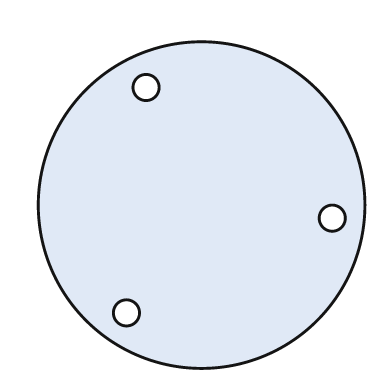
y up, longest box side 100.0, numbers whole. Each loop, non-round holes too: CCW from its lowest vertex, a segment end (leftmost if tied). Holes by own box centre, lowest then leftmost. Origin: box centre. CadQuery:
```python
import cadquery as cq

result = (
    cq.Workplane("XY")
    .moveTo(0.0, 0.0)
    .circle(50.0)
    .moveTo(-23.0, -33.0)
    .circle(4.0)
    .moveTo(40.0, -4.0)
    .circle(4.0)
    .moveTo(-17.0, 36.0)
    .circle(4.0)
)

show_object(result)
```